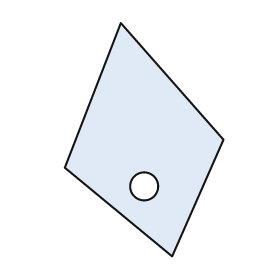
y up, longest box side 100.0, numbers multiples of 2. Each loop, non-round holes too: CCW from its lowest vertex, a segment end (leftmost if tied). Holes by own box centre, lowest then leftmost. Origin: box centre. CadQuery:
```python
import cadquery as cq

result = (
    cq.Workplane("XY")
    .moveTo(12.0, -50.0)
    .lineTo(34.0, 0.0)
    .lineTo(-10.0, 50.0)
    .lineTo(-34.0, -12.0)
    .close()
    .moveTo(0.0, -20.0)
    .circle(6.0)
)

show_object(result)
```